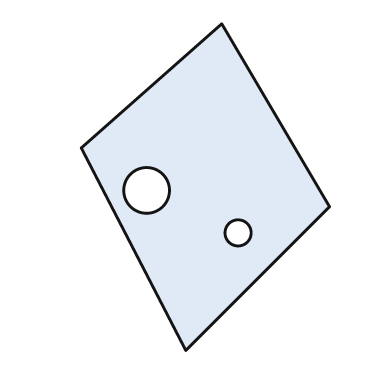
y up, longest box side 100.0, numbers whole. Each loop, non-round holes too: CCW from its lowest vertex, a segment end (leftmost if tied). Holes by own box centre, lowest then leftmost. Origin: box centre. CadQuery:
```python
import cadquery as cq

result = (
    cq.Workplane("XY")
    .moveTo(-6.0, -50.0)
    .lineTo(38.0, -6.0)
    .lineTo(5.0, 50.0)
    .lineTo(-38.0, 12.0)
    .close()
    .moveTo(10.0, -14.0)
    .circle(4.0)
    .moveTo(-18.0, -1.0)
    .circle(7.0)
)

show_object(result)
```